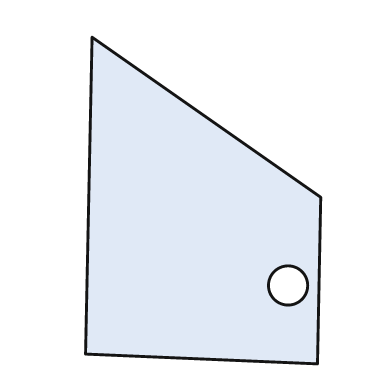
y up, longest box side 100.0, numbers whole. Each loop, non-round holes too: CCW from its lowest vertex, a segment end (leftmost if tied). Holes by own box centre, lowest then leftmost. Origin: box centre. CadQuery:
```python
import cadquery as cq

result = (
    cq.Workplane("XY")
    .moveTo(35.0, -50.0)
    .lineTo(36.0, 1.0)
    .lineTo(-34.0, 50.0)
    .lineTo(-36.0, -47.0)
    .close()
    .moveTo(26.0, -26.0)
    .circle(6.0)
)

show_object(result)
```